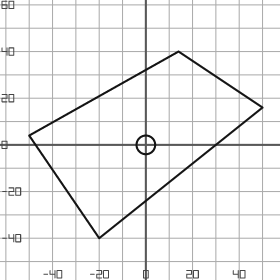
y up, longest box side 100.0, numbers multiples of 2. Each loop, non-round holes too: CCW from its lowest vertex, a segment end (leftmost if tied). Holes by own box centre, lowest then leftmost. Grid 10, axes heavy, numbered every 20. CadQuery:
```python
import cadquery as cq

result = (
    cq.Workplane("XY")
    .moveTo(-20.0, -40.0)
    .lineTo(50.0, 16.0)
    .lineTo(14.0, 40.0)
    .lineTo(-50.0, 4.0)
    .close()
    .moveTo(0.0, 0.0)
    .circle(4.0)
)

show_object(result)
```